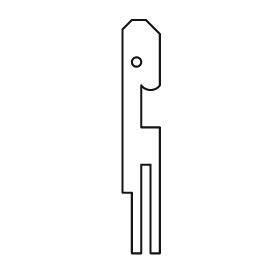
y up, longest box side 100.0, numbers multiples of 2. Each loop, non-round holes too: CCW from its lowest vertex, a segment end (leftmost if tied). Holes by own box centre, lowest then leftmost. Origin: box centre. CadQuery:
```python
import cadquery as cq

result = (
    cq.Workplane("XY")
    .moveTo(-4.0, -50.0)
    .lineTo(0.0, -50.0)
    .lineTo(0.0, -12.0)
    .lineTo(4.0, -12.0)
    .lineTo(4.0, -50.0)
    .lineTo(8.0, -50.0)
    .lineTo(8.0, 4.0)
    .lineTo(0.0, 4.0)
    .lineTo(0.0, 22.0)
    .threePointArc((4.0, 20.0), (8.0, 22.0))
    .lineTo(8.0, 44.0)
    .lineTo(2.0, 50.0)
    .lineTo(-4.0, 50.0)
    .lineTo(-8.0, 46.0)
    .lineTo(-8.0, -24.0)
    .lineTo(-4.0, -24.0)
    .close()
    .moveTo(-2.0, 32.0)
    .circle(2.0)
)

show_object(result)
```